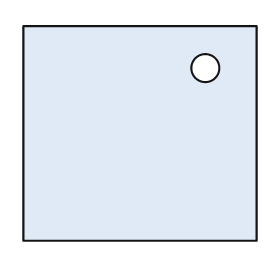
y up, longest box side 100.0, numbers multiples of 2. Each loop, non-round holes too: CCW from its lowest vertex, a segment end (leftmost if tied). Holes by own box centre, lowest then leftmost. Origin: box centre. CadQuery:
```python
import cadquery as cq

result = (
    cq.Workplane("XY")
    .moveTo(-50.0, -46.0)
    .lineTo(50.0, -46.0)
    .lineTo(50.0, 46.0)
    .lineTo(-50.0, 46.0)
    .close()
    .moveTo(28.0, 28.0)
    .circle(6.0)
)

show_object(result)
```